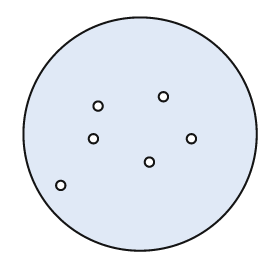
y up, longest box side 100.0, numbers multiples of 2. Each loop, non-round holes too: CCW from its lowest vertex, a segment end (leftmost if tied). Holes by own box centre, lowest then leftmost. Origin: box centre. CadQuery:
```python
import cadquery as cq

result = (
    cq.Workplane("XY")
    .moveTo(0.0, 0.0)
    .circle(50.0)
    .moveTo(-34.0, -22.0)
    .circle(2.0)
    .moveTo(4.0, -12.0)
    .circle(2.0)
    .moveTo(-20.0, -2.0)
    .circle(2.0)
    .moveTo(22.0, -2.0)
    .circle(2.0)
    .moveTo(-18.0, 12.0)
    .circle(2.0)
    .moveTo(10.0, 16.0)
    .circle(2.0)
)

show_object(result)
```